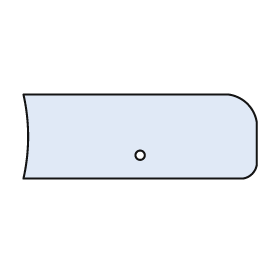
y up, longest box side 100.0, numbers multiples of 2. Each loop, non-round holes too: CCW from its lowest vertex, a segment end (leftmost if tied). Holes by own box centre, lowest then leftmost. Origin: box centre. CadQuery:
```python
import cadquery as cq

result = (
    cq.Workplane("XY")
    .moveTo(-50.0, -18.0)
    .lineTo(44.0, -18.0)
    .threePointArc((48.0, -16.0), (50.0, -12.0))
    .lineTo(50.0, 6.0)
    .threePointArc((46.0, 14.0), (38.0, 18.0))
    .lineTo(-50.0, 18.0)
    .threePointArc((-48.0, 0.0), (-50.0, -18.0))
    .close()
    .moveTo(0.0, -8.0)
    .circle(2.0)
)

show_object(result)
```